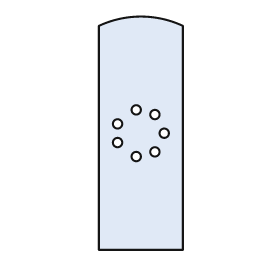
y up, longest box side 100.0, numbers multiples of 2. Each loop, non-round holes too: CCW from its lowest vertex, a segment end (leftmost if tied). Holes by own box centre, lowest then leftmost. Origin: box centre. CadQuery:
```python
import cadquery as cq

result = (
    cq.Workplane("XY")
    .moveTo(-18.0, -50.0)
    .lineTo(18.0, -50.0)
    .lineTo(18.0, 46.0)
    .threePointArc((0.0, 50.0), (-18.0, 46.0))
    .close()
    .moveTo(-2.0, -10.0)
    .circle(2.0)
    .moveTo(6.0, -8.0)
    .circle(2.0)
    .moveTo(-10.0, -4.0)
    .circle(2.0)
    .moveTo(10.0, 0.0)
    .circle(2.0)
    .moveTo(-10.0, 4.0)
    .circle(2.0)
    .moveTo(6.0, 8.0)
    .circle(2.0)
    .moveTo(-2.0, 10.0)
    .circle(2.0)
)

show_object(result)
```